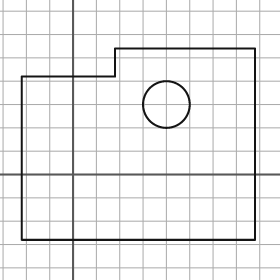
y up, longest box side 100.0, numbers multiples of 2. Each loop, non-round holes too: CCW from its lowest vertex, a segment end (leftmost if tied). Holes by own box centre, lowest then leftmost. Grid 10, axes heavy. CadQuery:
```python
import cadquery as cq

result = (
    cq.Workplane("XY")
    .moveTo(-22.0, -28.0)
    .lineTo(78.0, -28.0)
    .lineTo(78.0, 54.0)
    .lineTo(18.0, 54.0)
    .lineTo(18.0, 42.0)
    .lineTo(-22.0, 42.0)
    .close()
    .moveTo(40.0, 30.0)
    .circle(10.0)
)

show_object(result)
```